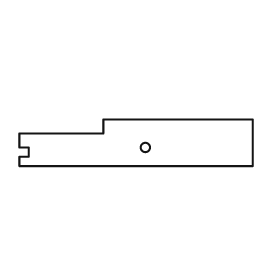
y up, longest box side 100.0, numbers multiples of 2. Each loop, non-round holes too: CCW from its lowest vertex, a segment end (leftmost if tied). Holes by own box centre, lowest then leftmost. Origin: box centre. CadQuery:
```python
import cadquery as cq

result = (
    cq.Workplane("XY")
    .moveTo(-50.0, -10.0)
    .lineTo(50.0, -10.0)
    .lineTo(50.0, 10.0)
    .lineTo(-14.0, 10.0)
    .lineTo(-14.0, 4.0)
    .lineTo(-50.0, 4.0)
    .lineTo(-50.0, -2.0)
    .lineTo(-46.0, -2.0)
    .lineTo(-46.0, -6.0)
    .lineTo(-50.0, -6.0)
    .close()
    .moveTo(4.0, -2.0)
    .circle(2.0)
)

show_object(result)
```